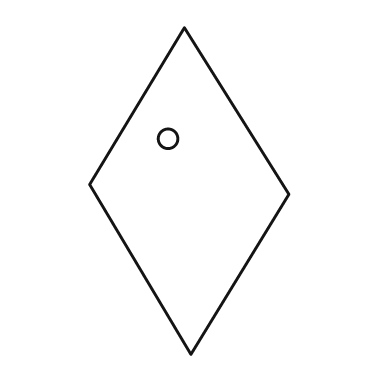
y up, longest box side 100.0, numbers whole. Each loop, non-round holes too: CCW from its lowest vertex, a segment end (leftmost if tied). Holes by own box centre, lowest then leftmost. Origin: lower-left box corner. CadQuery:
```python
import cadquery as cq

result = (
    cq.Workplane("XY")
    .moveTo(31.0, 0.0)
    .lineTo(61.0, 49.0)
    .lineTo(29.0, 100.0)
    .lineTo(0.0, 52.0)
    .close()
    .moveTo(24.0, 66.0)
    .circle(3.0)
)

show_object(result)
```